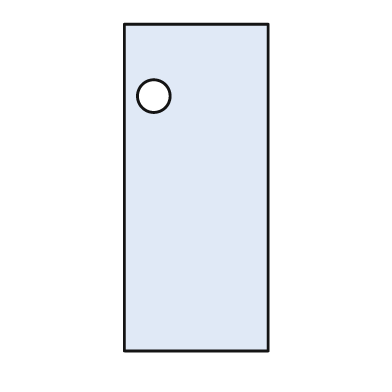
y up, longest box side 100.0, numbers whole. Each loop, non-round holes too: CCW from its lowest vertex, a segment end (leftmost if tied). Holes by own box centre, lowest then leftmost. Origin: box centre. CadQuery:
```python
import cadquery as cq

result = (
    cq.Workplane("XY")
    .moveTo(-22.0, -50.0)
    .lineTo(22.0, -50.0)
    .lineTo(22.0, 50.0)
    .lineTo(-22.0, 50.0)
    .close()
    .moveTo(-13.0, 28.0)
    .circle(5.0)
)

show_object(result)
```